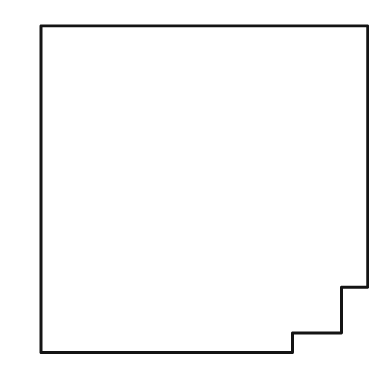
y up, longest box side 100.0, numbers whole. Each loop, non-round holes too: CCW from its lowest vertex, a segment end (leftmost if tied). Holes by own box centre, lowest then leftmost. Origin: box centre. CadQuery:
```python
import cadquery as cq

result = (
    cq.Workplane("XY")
    .moveTo(-50.0, -50.0)
    .lineTo(27.0, -50.0)
    .lineTo(27.0, -44.0)
    .lineTo(42.0, -44.0)
    .lineTo(42.0, -30.0)
    .lineTo(50.0, -30.0)
    .lineTo(50.0, 50.0)
    .lineTo(-50.0, 50.0)
    .close()
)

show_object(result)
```